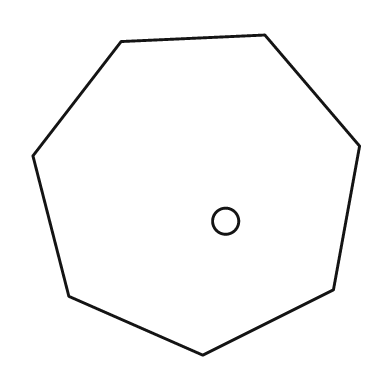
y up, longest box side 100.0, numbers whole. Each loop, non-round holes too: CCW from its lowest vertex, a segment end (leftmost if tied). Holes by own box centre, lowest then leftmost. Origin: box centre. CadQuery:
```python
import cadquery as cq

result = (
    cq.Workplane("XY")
    .moveTo(2.0, -49.0)
    .lineTo(42.0, -29.0)
    .lineTo(50.0, 15.0)
    .lineTo(21.0, 49.0)
    .lineTo(-23.0, 47.0)
    .lineTo(-50.0, 12.0)
    .lineTo(-39.0, -31.0)
    .close()
    .moveTo(9.0, -8.0)
    .circle(4.0)
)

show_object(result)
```